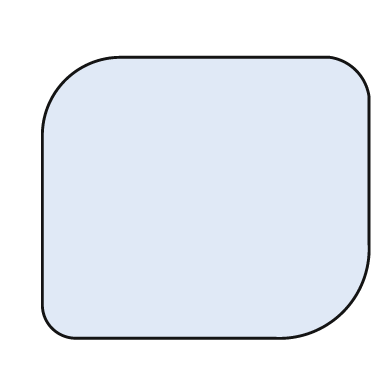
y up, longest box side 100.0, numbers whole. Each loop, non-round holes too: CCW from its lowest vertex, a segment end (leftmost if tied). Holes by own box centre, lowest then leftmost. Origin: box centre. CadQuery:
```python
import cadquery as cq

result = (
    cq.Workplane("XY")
    .moveTo(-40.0, -43.0)
    .lineTo(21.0, -43.0)
    .threePointArc((42.0, -35.0), (50.0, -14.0))
    .lineTo(50.0, 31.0)
    .threePointArc((46.0, 39.0), (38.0, 43.0))
    .lineTo(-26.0, 43.0)
    .threePointArc((-43.0, 36.0), (-50.0, 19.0))
    .lineTo(-50.0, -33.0)
    .threePointArc((-47.0, -40.0), (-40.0, -43.0))
    .close()
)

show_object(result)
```